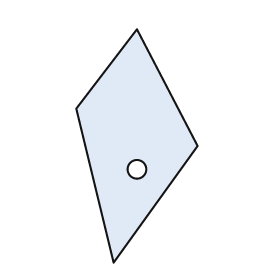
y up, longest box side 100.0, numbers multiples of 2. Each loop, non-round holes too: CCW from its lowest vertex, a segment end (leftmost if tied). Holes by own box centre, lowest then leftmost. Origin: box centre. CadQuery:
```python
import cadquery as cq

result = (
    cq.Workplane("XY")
    .moveTo(-10.0, -50.0)
    .lineTo(26.0, 0.0)
    .lineTo(0.0, 50.0)
    .lineTo(-26.0, 16.0)
    .close()
    .moveTo(0.0, -10.0)
    .circle(4.0)
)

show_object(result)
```